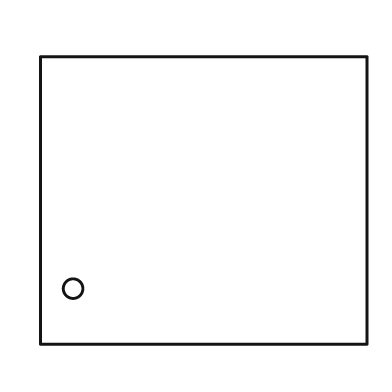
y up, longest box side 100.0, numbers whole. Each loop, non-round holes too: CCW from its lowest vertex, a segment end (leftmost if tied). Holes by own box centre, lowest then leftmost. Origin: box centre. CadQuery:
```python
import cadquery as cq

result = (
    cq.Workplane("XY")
    .moveTo(-50.0, -44.0)
    .lineTo(50.0, -44.0)
    .lineTo(50.0, 44.0)
    .lineTo(-50.0, 44.0)
    .close()
    .moveTo(-40.0, -27.0)
    .circle(3.0)
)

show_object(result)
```